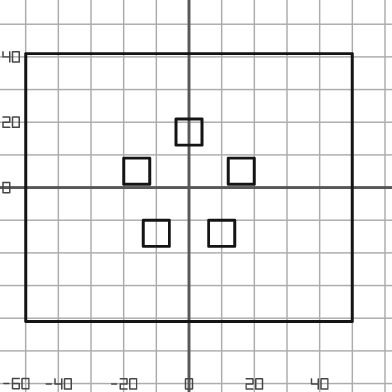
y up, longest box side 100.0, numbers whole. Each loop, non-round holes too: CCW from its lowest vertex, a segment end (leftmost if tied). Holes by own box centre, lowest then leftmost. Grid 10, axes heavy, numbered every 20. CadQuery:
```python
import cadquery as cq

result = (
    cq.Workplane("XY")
    .moveTo(-50.0, -41.0)
    .lineTo(50.0, -41.0)
    .lineTo(50.0, 41.0)
    .lineTo(-50.0, 41.0)
    .close()
    .moveTo(-14.0, -18.0)
    .lineTo(-6.0, -18.0)
    .lineTo(-6.0, -10.0)
    .lineTo(-14.0, -10.0)
    .close()
    .moveTo(6.0, -18.0)
    .lineTo(14.0, -18.0)
    .lineTo(14.0, -10.0)
    .lineTo(6.0, -10.0)
    .close()
    .moveTo(-20.0, 1.0)
    .lineTo(-12.0, 1.0)
    .lineTo(-12.0, 9.0)
    .lineTo(-20.0, 9.0)
    .close()
    .moveTo(12.0, 1.0)
    .lineTo(20.0, 1.0)
    .lineTo(20.0, 9.0)
    .lineTo(12.0, 9.0)
    .close()
    .moveTo(-4.0, 13.0)
    .lineTo(4.0, 13.0)
    .lineTo(4.0, 21.0)
    .lineTo(-4.0, 21.0)
    .close()
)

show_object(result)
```